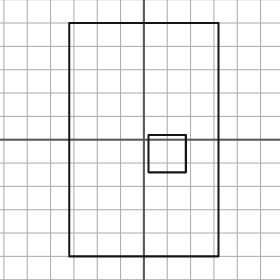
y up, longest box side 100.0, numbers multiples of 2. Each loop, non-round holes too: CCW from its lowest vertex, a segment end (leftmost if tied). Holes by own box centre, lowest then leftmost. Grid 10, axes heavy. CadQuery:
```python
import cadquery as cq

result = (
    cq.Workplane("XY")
    .moveTo(-32.0, -50.0)
    .lineTo(32.0, -50.0)
    .lineTo(32.0, 50.0)
    .lineTo(-32.0, 50.0)
    .close()
    .moveTo(2.0, -14.0)
    .lineTo(18.0, -14.0)
    .lineTo(18.0, 2.0)
    .lineTo(2.0, 2.0)
    .close()
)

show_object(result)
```